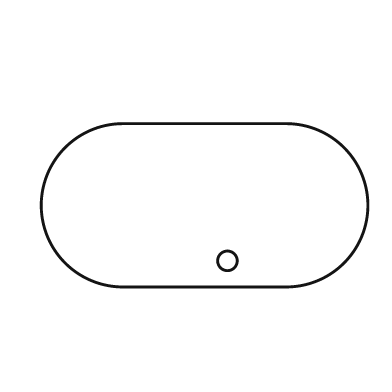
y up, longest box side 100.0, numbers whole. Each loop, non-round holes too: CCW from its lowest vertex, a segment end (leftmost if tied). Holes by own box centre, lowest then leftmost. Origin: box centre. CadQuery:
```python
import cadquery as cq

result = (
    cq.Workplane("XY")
    .moveTo(-25.0, -25.0)
    .lineTo(25.0, -25.0)
    .threePointArc((50.0, 0.0), (25.0, 25.0))
    .lineTo(-25.0, 25.0)
    .threePointArc((-50.0, 0.0), (-25.0, -25.0))
    .close()
    .moveTo(7.0, -17.0)
    .circle(3.0)
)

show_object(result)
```